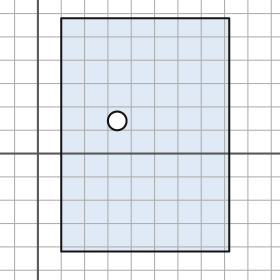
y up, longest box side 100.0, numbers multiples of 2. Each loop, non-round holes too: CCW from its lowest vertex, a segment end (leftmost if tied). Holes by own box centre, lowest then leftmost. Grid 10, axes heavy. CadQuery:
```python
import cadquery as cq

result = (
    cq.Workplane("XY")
    .moveTo(10.0, -42.0)
    .lineTo(82.0, -42.0)
    .lineTo(82.0, 58.0)
    .lineTo(10.0, 58.0)
    .close()
    .moveTo(34.0, 14.0)
    .circle(4.0)
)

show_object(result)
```